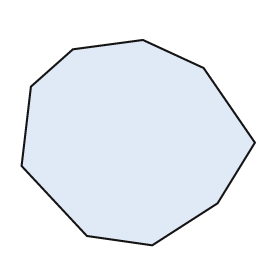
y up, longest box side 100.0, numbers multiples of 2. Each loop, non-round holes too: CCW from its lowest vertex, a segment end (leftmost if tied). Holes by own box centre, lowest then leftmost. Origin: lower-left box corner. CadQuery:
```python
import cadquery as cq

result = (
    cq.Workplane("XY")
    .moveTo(56.0, 0.0)
    .lineTo(84.0, 18.0)
    .lineTo(100.0, 44.0)
    .lineTo(78.0, 76.0)
    .lineTo(52.0, 88.0)
    .lineTo(22.0, 84.0)
    .lineTo(4.0, 68.0)
    .lineTo(0.0, 34.0)
    .lineTo(28.0, 4.0)
    .close()
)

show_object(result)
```